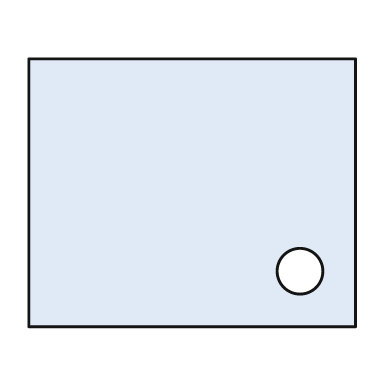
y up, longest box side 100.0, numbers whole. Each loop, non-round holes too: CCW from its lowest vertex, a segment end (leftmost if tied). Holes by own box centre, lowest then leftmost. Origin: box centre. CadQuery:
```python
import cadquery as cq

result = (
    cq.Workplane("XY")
    .moveTo(-50.0, -41.0)
    .lineTo(50.0, -41.0)
    .lineTo(50.0, 41.0)
    .lineTo(-50.0, 41.0)
    .close()
    .moveTo(33.0, -24.0)
    .circle(7.0)
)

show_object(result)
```